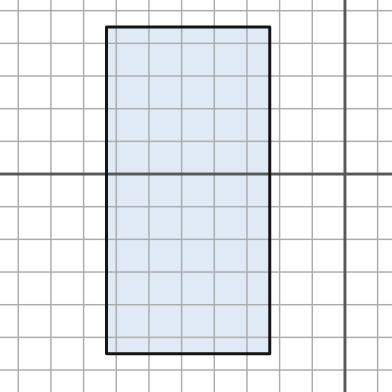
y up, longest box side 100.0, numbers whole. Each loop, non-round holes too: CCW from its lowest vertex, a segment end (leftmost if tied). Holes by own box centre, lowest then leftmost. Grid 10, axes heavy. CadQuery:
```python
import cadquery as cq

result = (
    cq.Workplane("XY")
    .moveTo(-73.0, -55.0)
    .lineTo(-23.0, -55.0)
    .lineTo(-23.0, 45.0)
    .lineTo(-73.0, 45.0)
    .close()
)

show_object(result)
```